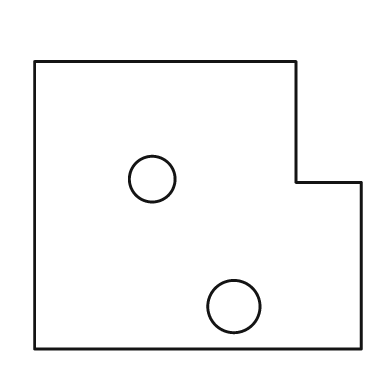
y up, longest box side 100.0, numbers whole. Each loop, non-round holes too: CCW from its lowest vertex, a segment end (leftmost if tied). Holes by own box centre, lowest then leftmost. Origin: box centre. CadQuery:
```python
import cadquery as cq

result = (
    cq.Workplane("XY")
    .moveTo(-50.0, -44.0)
    .lineTo(50.0, -44.0)
    .lineTo(50.0, 7.0)
    .lineTo(30.0, 7.0)
    .lineTo(30.0, 44.0)
    .lineTo(-50.0, 44.0)
    .close()
    .moveTo(11.0, -31.0)
    .circle(8.0)
    .moveTo(-14.0, 8.0)
    .circle(7.0)
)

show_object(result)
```